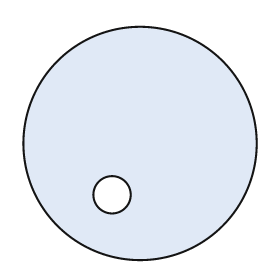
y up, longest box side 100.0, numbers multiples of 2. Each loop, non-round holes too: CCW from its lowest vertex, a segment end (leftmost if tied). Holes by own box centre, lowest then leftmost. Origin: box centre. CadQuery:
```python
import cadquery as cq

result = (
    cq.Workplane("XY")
    .moveTo(0.0, 0.0)
    .circle(50.0)
    .moveTo(-12.0, -22.0)
    .circle(8.0)
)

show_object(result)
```